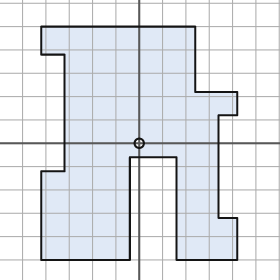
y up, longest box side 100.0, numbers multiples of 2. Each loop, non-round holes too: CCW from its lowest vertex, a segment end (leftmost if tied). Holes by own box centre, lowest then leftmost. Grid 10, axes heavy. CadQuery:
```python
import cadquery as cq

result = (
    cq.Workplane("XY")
    .moveTo(-42.0, -50.0)
    .lineTo(-4.0, -50.0)
    .lineTo(-4.0, -6.0)
    .lineTo(16.0, -6.0)
    .lineTo(16.0, -50.0)
    .lineTo(42.0, -50.0)
    .lineTo(42.0, -32.0)
    .lineTo(34.0, -32.0)
    .lineTo(34.0, 12.0)
    .lineTo(42.0, 12.0)
    .lineTo(42.0, 22.0)
    .lineTo(24.0, 22.0)
    .lineTo(24.0, 50.0)
    .lineTo(-42.0, 50.0)
    .lineTo(-42.0, 38.0)
    .lineTo(-32.0, 38.0)
    .lineTo(-32.0, -12.0)
    .lineTo(-42.0, -12.0)
    .close()
    .moveTo(0.0, 0.0)
    .circle(2.0)
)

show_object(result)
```